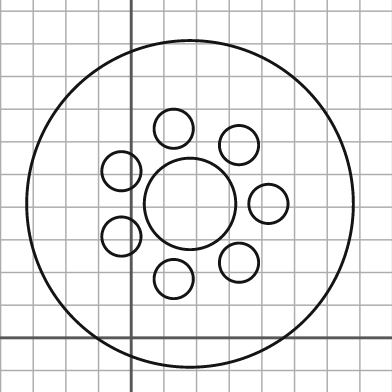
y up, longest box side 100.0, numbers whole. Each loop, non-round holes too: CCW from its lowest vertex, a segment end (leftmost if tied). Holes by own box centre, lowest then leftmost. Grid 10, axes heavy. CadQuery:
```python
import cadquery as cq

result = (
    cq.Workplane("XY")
    .moveTo(18.0, 41.0)
    .circle(50.0)
    .moveTo(13.0, 18.0)
    .circle(6.0)
    .moveTo(33.0, 23.0)
    .circle(6.0)
    .moveTo(-3.0, 31.0)
    .circle(6.0)
    .moveTo(18.0, 41.0)
    .circle(14.0)
    .moveTo(42.0, 41.0)
    .circle(6.0)
    .moveTo(-3.0, 51.0)
    .circle(6.0)
    .moveTo(33.0, 59.0)
    .circle(6.0)
    .moveTo(13.0, 64.0)
    .circle(6.0)
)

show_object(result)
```